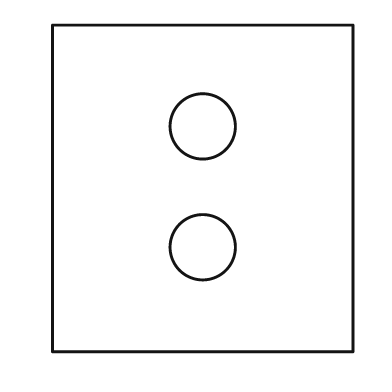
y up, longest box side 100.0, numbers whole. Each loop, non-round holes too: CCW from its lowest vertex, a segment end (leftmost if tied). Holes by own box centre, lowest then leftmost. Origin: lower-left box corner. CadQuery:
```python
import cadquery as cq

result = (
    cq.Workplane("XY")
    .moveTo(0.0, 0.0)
    .lineTo(92.0, 0.0)
    .lineTo(92.0, 100.0)
    .lineTo(0.0, 100.0)
    .close()
    .moveTo(46.0, 32.0)
    .circle(10.0)
    .moveTo(46.0, 69.0)
    .circle(10.0)
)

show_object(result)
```